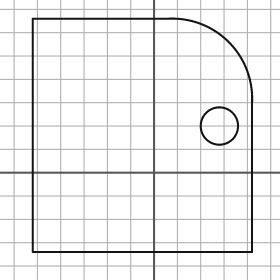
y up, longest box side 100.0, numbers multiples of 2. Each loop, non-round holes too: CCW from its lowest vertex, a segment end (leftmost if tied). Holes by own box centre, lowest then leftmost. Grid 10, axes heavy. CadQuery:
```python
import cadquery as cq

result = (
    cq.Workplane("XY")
    .moveTo(-52.0, -34.0)
    .lineTo(42.0, -34.0)
    .lineTo(42.0, 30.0)
    .threePointArc((32.0, 56.0), (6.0, 66.0))
    .lineTo(-52.0, 66.0)
    .close()
    .moveTo(28.0, 20.0)
    .circle(8.0)
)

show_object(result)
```